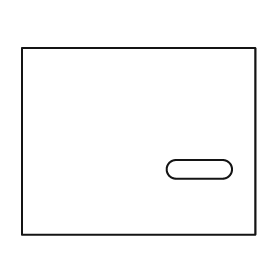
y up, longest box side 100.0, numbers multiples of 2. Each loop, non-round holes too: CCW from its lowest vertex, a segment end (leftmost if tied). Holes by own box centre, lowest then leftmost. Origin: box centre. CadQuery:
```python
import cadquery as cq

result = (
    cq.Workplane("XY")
    .moveTo(-50.0, -40.0)
    .lineTo(50.0, -40.0)
    .lineTo(50.0, 40.0)
    .lineTo(-50.0, 40.0)
    .close()
    .moveTo(16.0, -16.0)
    .lineTo(36.0, -16.0)
    .threePointArc((40.0, -12.0), (36.0, -8.0))
    .lineTo(16.0, -8.0)
    .threePointArc((12.0, -12.0), (16.0, -16.0))
    .close()
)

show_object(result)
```